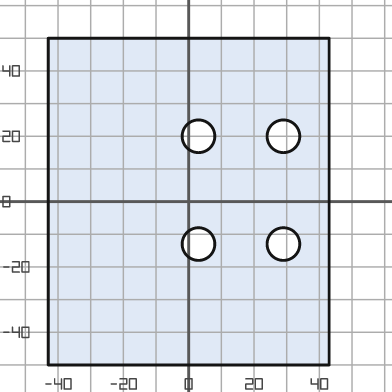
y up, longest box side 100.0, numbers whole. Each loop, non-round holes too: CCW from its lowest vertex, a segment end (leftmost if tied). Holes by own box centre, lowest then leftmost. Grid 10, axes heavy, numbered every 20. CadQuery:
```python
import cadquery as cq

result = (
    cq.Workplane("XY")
    .moveTo(-43.0, -50.0)
    .lineTo(43.0, -50.0)
    .lineTo(43.0, 50.0)
    .lineTo(-43.0, 50.0)
    .close()
    .moveTo(3.0, -13.0)
    .circle(5.0)
    .moveTo(29.0, -13.0)
    .circle(5.0)
    .moveTo(3.0, 20.0)
    .circle(5.0)
    .moveTo(29.0, 20.0)
    .circle(5.0)
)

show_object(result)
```